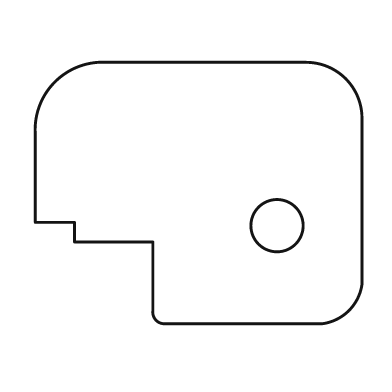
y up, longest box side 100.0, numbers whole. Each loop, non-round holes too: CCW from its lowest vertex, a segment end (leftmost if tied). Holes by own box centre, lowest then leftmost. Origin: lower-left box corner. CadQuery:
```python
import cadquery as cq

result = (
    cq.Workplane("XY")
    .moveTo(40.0, 0.0)
    .lineTo(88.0, 0.0)
    .threePointArc((96.0, 4.0), (100.0, 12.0))
    .lineTo(100.0, 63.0)
    .threePointArc((95.0, 75.0), (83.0, 80.0))
    .lineTo(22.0, 80.0)
    .threePointArc((6.0, 74.0), (0.0, 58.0))
    .lineTo(0.0, 31.0)
    .lineTo(12.0, 31.0)
    .lineTo(12.0, 25.0)
    .lineTo(36.0, 25.0)
    .lineTo(36.0, 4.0)
    .threePointArc((37.0, 1.0), (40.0, 0.0))
    .close()
    .moveTo(74.0, 30.0)
    .circle(8.0)
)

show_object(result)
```